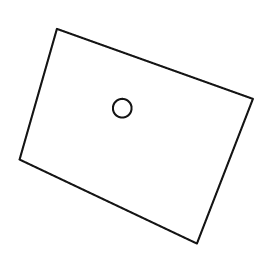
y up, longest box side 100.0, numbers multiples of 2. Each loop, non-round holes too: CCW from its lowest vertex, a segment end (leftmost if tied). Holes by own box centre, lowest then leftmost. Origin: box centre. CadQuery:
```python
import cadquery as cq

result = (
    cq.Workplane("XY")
    .moveTo(26.0, -46.0)
    .lineTo(50.0, 16.0)
    .lineTo(-34.0, 46.0)
    .lineTo(-50.0, -10.0)
    .close()
    .moveTo(-6.0, 12.0)
    .circle(4.0)
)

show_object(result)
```